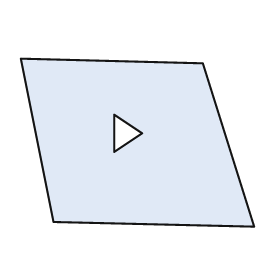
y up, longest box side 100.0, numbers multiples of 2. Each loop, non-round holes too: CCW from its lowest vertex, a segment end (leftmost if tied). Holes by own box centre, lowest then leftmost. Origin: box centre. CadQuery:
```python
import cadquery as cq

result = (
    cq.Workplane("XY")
    .moveTo(50.0, -36.0)
    .lineTo(28.0, 34.0)
    .lineTo(-50.0, 36.0)
    .lineTo(-36.0, -34.0)
    .close()
    .moveTo(-10.0, -4.0)
    .lineTo(2.0, 4.0)
    .lineTo(-10.0, 12.0)
    .close()
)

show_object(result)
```